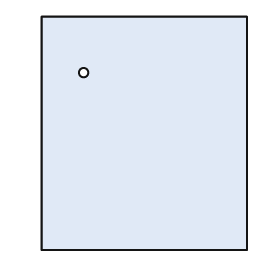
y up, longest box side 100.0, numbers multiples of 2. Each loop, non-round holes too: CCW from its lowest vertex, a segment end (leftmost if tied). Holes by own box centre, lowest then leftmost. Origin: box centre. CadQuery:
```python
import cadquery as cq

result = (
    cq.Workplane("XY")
    .moveTo(-44.0, -50.0)
    .lineTo(44.0, -50.0)
    .lineTo(44.0, 50.0)
    .lineTo(-44.0, 50.0)
    .close()
    .moveTo(-26.0, 26.0)
    .circle(2.0)
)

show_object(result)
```